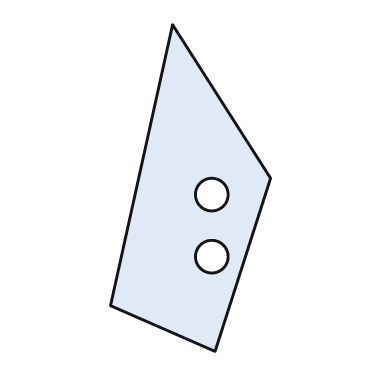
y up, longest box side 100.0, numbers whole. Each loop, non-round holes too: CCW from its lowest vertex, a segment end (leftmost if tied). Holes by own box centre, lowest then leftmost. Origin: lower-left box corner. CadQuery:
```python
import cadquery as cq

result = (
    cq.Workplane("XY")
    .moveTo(32.0, 0.0)
    .lineTo(49.0, 53.0)
    .lineTo(19.0, 100.0)
    .lineTo(0.0, 14.0)
    .close()
    .moveTo(31.0, 29.0)
    .circle(5.0)
    .moveTo(31.0, 48.0)
    .circle(5.0)
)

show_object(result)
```